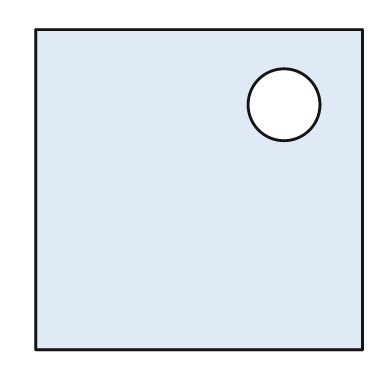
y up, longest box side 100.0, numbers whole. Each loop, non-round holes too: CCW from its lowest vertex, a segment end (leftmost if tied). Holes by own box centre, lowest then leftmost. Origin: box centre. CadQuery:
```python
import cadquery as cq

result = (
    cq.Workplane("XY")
    .moveTo(-50.0, -49.0)
    .lineTo(50.0, -49.0)
    .lineTo(50.0, 49.0)
    .lineTo(-50.0, 49.0)
    .close()
    .moveTo(26.0, 26.0)
    .circle(11.0)
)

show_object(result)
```